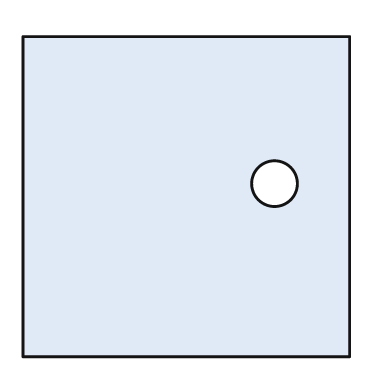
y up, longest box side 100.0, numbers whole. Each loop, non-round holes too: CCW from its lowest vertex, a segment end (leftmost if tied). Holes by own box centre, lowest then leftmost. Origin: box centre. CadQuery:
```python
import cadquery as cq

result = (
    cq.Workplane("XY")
    .moveTo(-50.0, -49.0)
    .lineTo(50.0, -49.0)
    .lineTo(50.0, 49.0)
    .lineTo(-50.0, 49.0)
    .close()
    .moveTo(27.0, 4.0)
    .circle(7.0)
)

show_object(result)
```